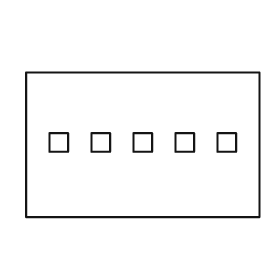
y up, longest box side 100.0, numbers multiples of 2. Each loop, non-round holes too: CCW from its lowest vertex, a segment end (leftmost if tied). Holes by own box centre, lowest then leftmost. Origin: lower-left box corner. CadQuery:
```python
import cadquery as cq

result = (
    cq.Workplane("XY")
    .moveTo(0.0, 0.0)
    .lineTo(100.0, 0.0)
    .lineTo(100.0, 62.0)
    .lineTo(0.0, 62.0)
    .close()
    .moveTo(10.0, 28.0)
    .lineTo(18.0, 28.0)
    .lineTo(18.0, 36.0)
    .lineTo(10.0, 36.0)
    .close()
    .moveTo(28.0, 28.0)
    .lineTo(36.0, 28.0)
    .lineTo(36.0, 36.0)
    .lineTo(28.0, 36.0)
    .close()
    .moveTo(46.0, 28.0)
    .lineTo(54.0, 28.0)
    .lineTo(54.0, 36.0)
    .lineTo(46.0, 36.0)
    .close()
    .moveTo(64.0, 28.0)
    .lineTo(72.0, 28.0)
    .lineTo(72.0, 36.0)
    .lineTo(64.0, 36.0)
    .close()
    .moveTo(82.0, 28.0)
    .lineTo(90.0, 28.0)
    .lineTo(90.0, 36.0)
    .lineTo(82.0, 36.0)
    .close()
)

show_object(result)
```